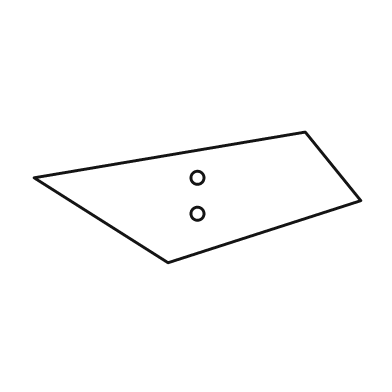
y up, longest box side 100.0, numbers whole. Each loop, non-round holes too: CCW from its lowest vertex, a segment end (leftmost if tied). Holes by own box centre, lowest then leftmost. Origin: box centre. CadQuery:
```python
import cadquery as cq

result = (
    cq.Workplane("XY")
    .moveTo(-9.0, -20.0)
    .lineTo(50.0, -1.0)
    .lineTo(33.0, 20.0)
    .lineTo(-50.0, 6.0)
    .close()
    .moveTo(0.0, -5.0)
    .circle(2.0)
    .moveTo(0.0, 6.0)
    .circle(2.0)
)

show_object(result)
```